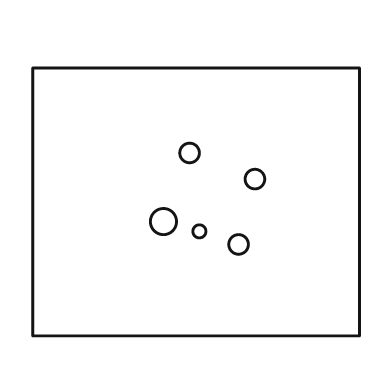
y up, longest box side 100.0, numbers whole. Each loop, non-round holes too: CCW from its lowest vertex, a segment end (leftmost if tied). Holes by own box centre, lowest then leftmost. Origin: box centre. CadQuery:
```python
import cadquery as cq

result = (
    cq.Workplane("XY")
    .moveTo(-50.0, -41.0)
    .lineTo(50.0, -41.0)
    .lineTo(50.0, 41.0)
    .lineTo(-50.0, 41.0)
    .close()
    .moveTo(13.0, -13.0)
    .circle(3.0)
    .moveTo(1.0, -9.0)
    .circle(2.0)
    .moveTo(-10.0, -6.0)
    .circle(4.0)
    .moveTo(18.0, 7.0)
    .circle(3.0)
    .moveTo(-2.0, 15.0)
    .circle(3.0)
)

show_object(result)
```